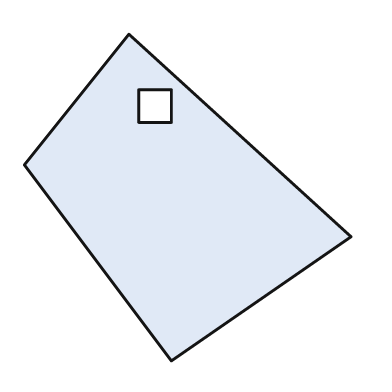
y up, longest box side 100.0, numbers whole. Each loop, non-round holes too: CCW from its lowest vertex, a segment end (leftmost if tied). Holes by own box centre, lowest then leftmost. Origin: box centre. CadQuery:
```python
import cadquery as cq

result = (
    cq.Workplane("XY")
    .moveTo(-5.0, -50.0)
    .lineTo(50.0, -12.0)
    .lineTo(-18.0, 50.0)
    .lineTo(-50.0, 10.0)
    .close()
    .moveTo(-15.0, 23.0)
    .lineTo(-5.0, 23.0)
    .lineTo(-5.0, 33.0)
    .lineTo(-15.0, 33.0)
    .close()
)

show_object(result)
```